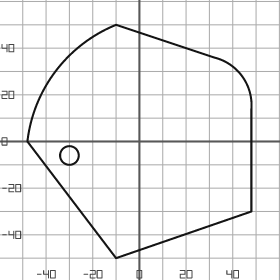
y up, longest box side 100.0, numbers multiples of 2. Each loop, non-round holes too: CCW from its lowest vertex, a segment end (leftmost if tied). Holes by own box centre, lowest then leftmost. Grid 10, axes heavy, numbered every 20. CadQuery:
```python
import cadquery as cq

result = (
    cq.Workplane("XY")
    .moveTo(-10.0, -50.0)
    .lineTo(48.0, -30.0)
    .lineTo(48.0, 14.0)
    .threePointArc((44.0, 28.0), (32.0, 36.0))
    .lineTo(-10.0, 50.0)
    .threePointArc((-36.0, 30.0), (-48.0, 0.0))
    .close()
    .moveTo(-30.0, -6.0)
    .circle(4.0)
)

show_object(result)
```